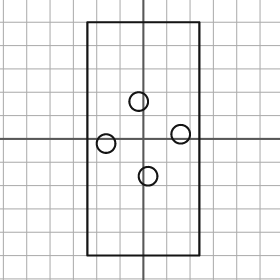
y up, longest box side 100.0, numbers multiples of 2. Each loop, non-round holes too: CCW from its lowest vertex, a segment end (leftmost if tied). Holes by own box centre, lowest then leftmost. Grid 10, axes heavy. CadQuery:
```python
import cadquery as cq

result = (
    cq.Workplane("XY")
    .moveTo(-24.0, -50.0)
    .lineTo(24.0, -50.0)
    .lineTo(24.0, 50.0)
    .lineTo(-24.0, 50.0)
    .close()
    .moveTo(2.0, -16.0)
    .circle(4.0)
    .moveTo(-16.0, -2.0)
    .circle(4.0)
    .moveTo(16.0, 2.0)
    .circle(4.0)
    .moveTo(-2.0, 16.0)
    .circle(4.0)
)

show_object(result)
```